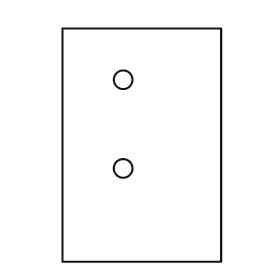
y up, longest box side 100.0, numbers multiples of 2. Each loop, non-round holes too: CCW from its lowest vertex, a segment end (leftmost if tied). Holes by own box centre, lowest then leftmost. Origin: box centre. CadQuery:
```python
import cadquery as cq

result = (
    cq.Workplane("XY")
    .moveTo(-34.0, -50.0)
    .lineTo(34.0, -50.0)
    .lineTo(34.0, 50.0)
    .lineTo(-34.0, 50.0)
    .close()
    .moveTo(-8.0, -10.0)
    .circle(4.0)
    .moveTo(-8.0, 28.0)
    .circle(4.0)
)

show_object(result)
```